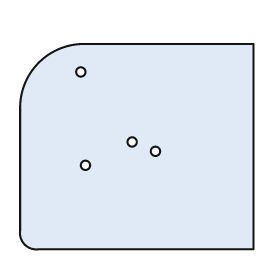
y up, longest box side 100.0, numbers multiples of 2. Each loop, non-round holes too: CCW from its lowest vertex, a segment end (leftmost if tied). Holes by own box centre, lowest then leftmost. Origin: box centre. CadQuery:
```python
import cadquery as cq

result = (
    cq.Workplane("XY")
    .moveTo(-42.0, -44.0)
    .lineTo(50.0, -44.0)
    .lineTo(50.0, 44.0)
    .lineTo(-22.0, 44.0)
    .threePointArc((-42.0, 36.0), (-50.0, 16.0))
    .lineTo(-50.0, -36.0)
    .threePointArc((-48.0, -42.0), (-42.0, -44.0))
    .close()
    .moveTo(-22.0, -8.0)
    .circle(2.0)
    .moveTo(8.0, -2.0)
    .circle(2.0)
    .moveTo(-2.0, 2.0)
    .circle(2.0)
    .moveTo(-24.0, 32.0)
    .circle(2.0)
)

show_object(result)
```